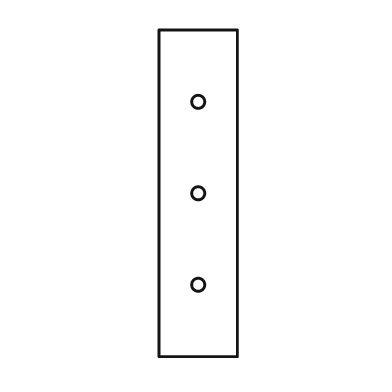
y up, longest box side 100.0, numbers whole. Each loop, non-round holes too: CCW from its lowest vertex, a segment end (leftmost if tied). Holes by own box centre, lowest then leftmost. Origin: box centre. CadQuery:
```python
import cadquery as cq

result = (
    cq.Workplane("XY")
    .moveTo(-12.0, -50.0)
    .lineTo(12.0, -50.0)
    .lineTo(12.0, 50.0)
    .lineTo(-12.0, 50.0)
    .close()
    .moveTo(0.0, -28.0)
    .circle(2.0)
    .moveTo(0.0, 0.0)
    .circle(2.0)
    .moveTo(0.0, 28.0)
    .circle(2.0)
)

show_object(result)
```